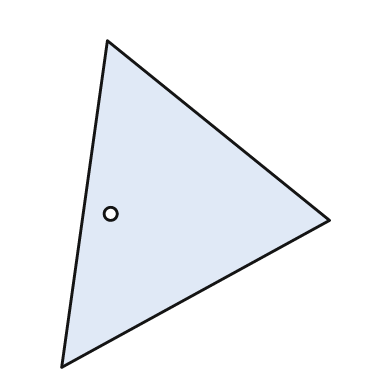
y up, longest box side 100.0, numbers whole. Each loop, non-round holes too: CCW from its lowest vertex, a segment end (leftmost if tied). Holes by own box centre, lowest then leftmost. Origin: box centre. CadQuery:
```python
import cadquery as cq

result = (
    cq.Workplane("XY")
    .moveTo(-41.0, -50.0)
    .lineTo(41.0, -5.0)
    .lineTo(-27.0, 50.0)
    .close()
    .moveTo(-26.0, -3.0)
    .circle(2.0)
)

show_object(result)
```